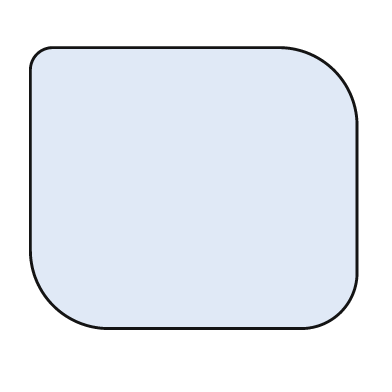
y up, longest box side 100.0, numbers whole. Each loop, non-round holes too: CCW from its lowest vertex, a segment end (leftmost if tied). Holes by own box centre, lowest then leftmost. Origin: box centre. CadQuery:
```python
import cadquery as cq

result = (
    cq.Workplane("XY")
    .moveTo(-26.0, -43.0)
    .lineTo(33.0, -43.0)
    .threePointArc((45.0, -38.0), (50.0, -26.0))
    .lineTo(50.0, 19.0)
    .threePointArc((43.0, 36.0), (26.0, 43.0))
    .lineTo(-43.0, 43.0)
    .threePointArc((-48.0, 41.0), (-50.0, 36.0))
    .lineTo(-50.0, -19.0)
    .threePointArc((-43.0, -36.0), (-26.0, -43.0))
    .close()
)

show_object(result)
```